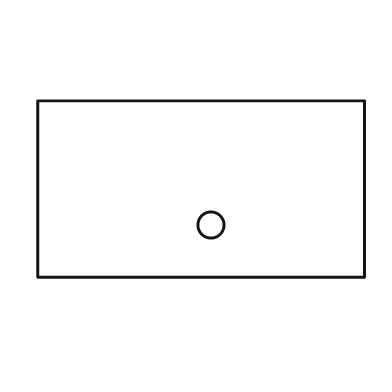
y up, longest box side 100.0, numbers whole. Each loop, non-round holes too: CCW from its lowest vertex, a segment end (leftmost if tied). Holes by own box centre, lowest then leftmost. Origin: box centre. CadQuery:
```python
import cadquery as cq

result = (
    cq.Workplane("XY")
    .moveTo(-50.0, -27.0)
    .lineTo(50.0, -27.0)
    .lineTo(50.0, 27.0)
    .lineTo(-50.0, 27.0)
    .close()
    .moveTo(3.0, -11.0)
    .circle(4.0)
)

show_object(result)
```